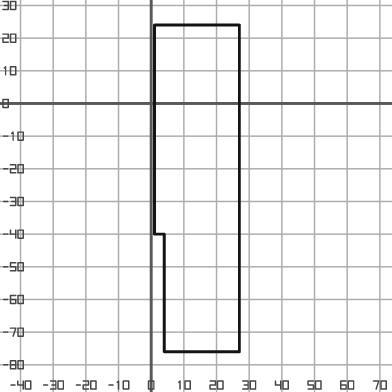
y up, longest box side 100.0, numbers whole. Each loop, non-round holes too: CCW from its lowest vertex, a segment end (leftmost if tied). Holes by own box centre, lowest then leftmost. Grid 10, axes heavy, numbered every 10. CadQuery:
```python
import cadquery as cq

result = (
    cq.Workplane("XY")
    .moveTo(4.0, -76.0)
    .lineTo(27.0, -76.0)
    .lineTo(27.0, 24.0)
    .lineTo(1.0, 24.0)
    .lineTo(1.0, -40.0)
    .lineTo(4.0, -40.0)
    .close()
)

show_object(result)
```